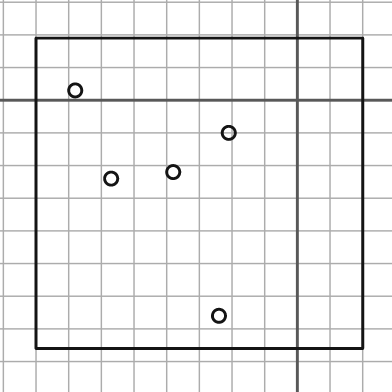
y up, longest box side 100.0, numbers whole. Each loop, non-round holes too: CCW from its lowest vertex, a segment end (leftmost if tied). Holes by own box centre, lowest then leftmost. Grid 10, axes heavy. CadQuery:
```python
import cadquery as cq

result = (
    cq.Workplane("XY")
    .moveTo(-80.0, -76.0)
    .lineTo(20.0, -76.0)
    .lineTo(20.0, 19.0)
    .lineTo(-80.0, 19.0)
    .close()
    .moveTo(-24.0, -66.0)
    .circle(2.0)
    .moveTo(-57.0, -24.0)
    .circle(2.0)
    .moveTo(-38.0, -22.0)
    .circle(2.0)
    .moveTo(-21.0, -10.0)
    .circle(2.0)
    .moveTo(-68.0, 3.0)
    .circle(2.0)
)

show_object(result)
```